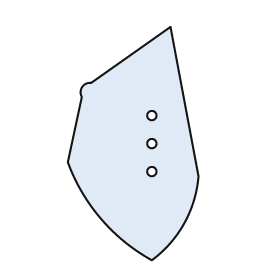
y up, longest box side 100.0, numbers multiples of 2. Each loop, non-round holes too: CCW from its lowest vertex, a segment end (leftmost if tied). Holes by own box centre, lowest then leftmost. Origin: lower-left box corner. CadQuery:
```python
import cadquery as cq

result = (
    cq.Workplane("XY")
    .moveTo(36.0, 0.0)
    .threePointArc((50.0, 16.0), (56.0, 36.0))
    .lineTo(44.0, 100.0)
    .lineTo(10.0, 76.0)
    .threePointArc((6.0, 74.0), (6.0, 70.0))
    .lineTo(0.0, 42.0)
    .threePointArc((14.0, 18.0), (36.0, 0.0))
    .close()
    .moveTo(36.0, 38.0)
    .circle(2.0)
    .moveTo(36.0, 50.0)
    .circle(2.0)
    .moveTo(36.0, 62.0)
    .circle(2.0)
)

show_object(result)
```